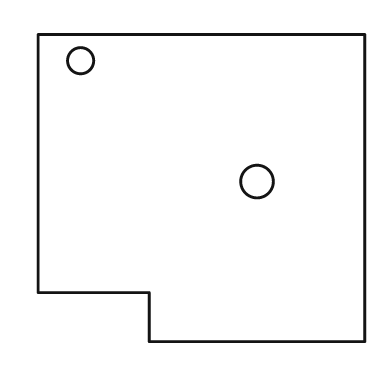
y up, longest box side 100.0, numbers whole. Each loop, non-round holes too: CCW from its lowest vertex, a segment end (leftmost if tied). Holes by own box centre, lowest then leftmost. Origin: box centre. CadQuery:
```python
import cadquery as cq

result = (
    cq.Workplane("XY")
    .moveTo(-16.0, -47.0)
    .lineTo(50.0, -47.0)
    .lineTo(50.0, 47.0)
    .lineTo(-50.0, 47.0)
    .lineTo(-50.0, -32.0)
    .lineTo(-16.0, -32.0)
    .close()
    .moveTo(17.0, 2.0)
    .circle(5.0)
    .moveTo(-37.0, 39.0)
    .circle(4.0)
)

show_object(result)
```